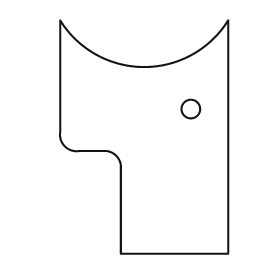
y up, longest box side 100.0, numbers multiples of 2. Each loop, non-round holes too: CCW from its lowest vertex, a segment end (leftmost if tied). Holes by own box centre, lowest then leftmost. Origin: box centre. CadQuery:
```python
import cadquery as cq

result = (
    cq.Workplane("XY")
    .moveTo(-10.0, -50.0)
    .lineTo(36.0, -50.0)
    .lineTo(36.0, 50.0)
    .threePointArc((0.0, 30.0), (-36.0, 50.0))
    .lineTo(-36.0, 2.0)
    .threePointArc((-34.0, -4.0), (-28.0, -6.0))
    .lineTo(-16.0, -6.0)
    .threePointArc((-12.0, -8.0), (-10.0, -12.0))
    .close()
    .moveTo(20.0, 12.0)
    .circle(4.0)
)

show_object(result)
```